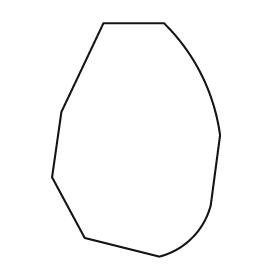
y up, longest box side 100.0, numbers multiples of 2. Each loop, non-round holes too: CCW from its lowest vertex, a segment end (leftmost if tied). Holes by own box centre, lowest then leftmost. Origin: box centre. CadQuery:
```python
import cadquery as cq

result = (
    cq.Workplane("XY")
    .moveTo(10.0, -50.0)
    .threePointArc((24.0, -42.0), (32.0, -28.0))
    .lineTo(36.0, 2.0)
    .threePointArc((28.0, 28.0), (12.0, 50.0))
    .lineTo(-14.0, 50.0)
    .lineTo(-32.0, 12.0)
    .lineTo(-36.0, -16.0)
    .lineTo(-22.0, -42.0)
    .close()
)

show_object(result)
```